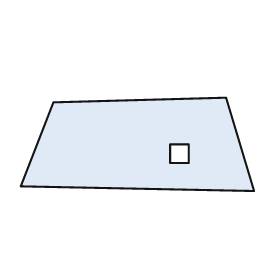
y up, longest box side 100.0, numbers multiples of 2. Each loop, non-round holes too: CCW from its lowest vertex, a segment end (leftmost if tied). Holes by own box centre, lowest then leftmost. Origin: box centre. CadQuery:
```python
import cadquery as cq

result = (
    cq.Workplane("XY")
    .moveTo(50.0, -20.0)
    .lineTo(38.0, 20.0)
    .lineTo(-36.0, 18.0)
    .lineTo(-50.0, -18.0)
    .close()
    .moveTo(14.0, -8.0)
    .lineTo(22.0, -8.0)
    .lineTo(22.0, 0.0)
    .lineTo(14.0, 0.0)
    .close()
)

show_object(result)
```